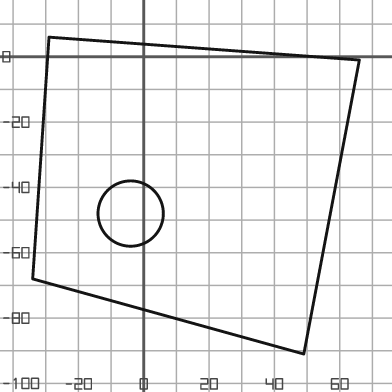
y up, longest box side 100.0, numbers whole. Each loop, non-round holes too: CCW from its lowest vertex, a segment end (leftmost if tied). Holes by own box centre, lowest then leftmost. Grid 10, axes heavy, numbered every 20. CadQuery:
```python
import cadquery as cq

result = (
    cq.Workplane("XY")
    .moveTo(49.0, -91.0)
    .lineTo(66.0, -1.0)
    .lineTo(-29.0, 6.0)
    .lineTo(-34.0, -68.0)
    .close()
    .moveTo(-4.0, -48.0)
    .circle(10.0)
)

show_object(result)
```